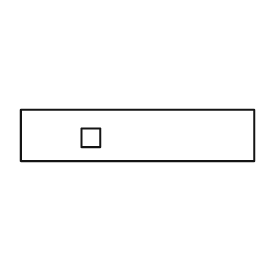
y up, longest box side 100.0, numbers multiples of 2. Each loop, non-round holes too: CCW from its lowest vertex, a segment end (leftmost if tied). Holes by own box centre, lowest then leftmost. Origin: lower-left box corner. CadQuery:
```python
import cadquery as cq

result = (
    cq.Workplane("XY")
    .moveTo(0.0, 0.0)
    .lineTo(100.0, 0.0)
    .lineTo(100.0, 22.0)
    .lineTo(0.0, 22.0)
    .close()
    .moveTo(26.0, 6.0)
    .lineTo(34.0, 6.0)
    .lineTo(34.0, 14.0)
    .lineTo(26.0, 14.0)
    .close()
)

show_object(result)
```